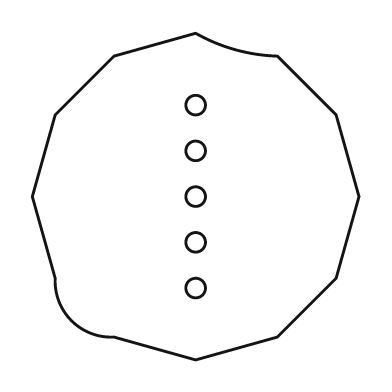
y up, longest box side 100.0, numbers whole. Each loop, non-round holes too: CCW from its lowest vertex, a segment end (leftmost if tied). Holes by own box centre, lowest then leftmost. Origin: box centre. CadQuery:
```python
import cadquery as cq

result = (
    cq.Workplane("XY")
    .moveTo(0.0, -50.0)
    .lineTo(25.0, -43.0)
    .lineTo(43.0, -25.0)
    .lineTo(50.0, 0.0)
    .lineTo(43.0, 25.0)
    .lineTo(25.0, 43.0)
    .threePointArc((12.0, 45.0), (0.0, 50.0))
    .lineTo(-25.0, 43.0)
    .lineTo(-43.0, 25.0)
    .lineTo(-50.0, 0.0)
    .lineTo(-43.0, -25.0)
    .threePointArc((-38.0, -38.0), (-25.0, -43.0))
    .close()
    .moveTo(0.0, -28.0)
    .circle(3.0)
    .moveTo(0.0, -14.0)
    .circle(3.0)
    .moveTo(0.0, 0.0)
    .circle(3.0)
    .moveTo(0.0, 14.0)
    .circle(3.0)
    .moveTo(0.0, 28.0)
    .circle(3.0)
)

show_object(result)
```